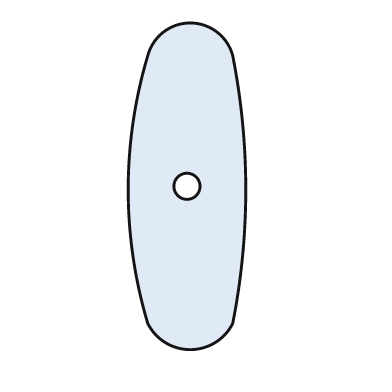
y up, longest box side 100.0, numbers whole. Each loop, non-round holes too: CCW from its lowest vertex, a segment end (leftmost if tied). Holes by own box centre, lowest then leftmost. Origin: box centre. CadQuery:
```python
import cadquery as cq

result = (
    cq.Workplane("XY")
    .moveTo(-12.0, -42.0)
    .threePointArc((1.0, -50.0), (14.0, -42.0))
    .threePointArc((18.0, -1.0), (14.0, 40.0))
    .threePointArc((1.0, 50.0), (-12.0, 40.0))
    .threePointArc((-18.0, -1.0), (-12.0, -42.0))
    .close()
    .moveTo(0.0, 0.0)
    .circle(4.0)
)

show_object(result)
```